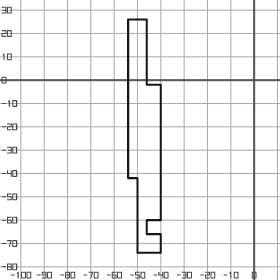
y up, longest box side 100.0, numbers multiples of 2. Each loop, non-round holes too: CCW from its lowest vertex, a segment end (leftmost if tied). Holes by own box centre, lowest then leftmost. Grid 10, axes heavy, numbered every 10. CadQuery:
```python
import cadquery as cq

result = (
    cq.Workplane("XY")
    .moveTo(-50.0, -74.0)
    .lineTo(-40.0, -74.0)
    .lineTo(-40.0, -66.0)
    .lineTo(-46.0, -66.0)
    .lineTo(-46.0, -60.0)
    .lineTo(-40.0, -60.0)
    .lineTo(-40.0, -2.0)
    .lineTo(-46.0, -2.0)
    .lineTo(-46.0, 26.0)
    .lineTo(-54.0, 26.0)
    .lineTo(-54.0, -42.0)
    .lineTo(-50.0, -42.0)
    .close()
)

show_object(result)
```